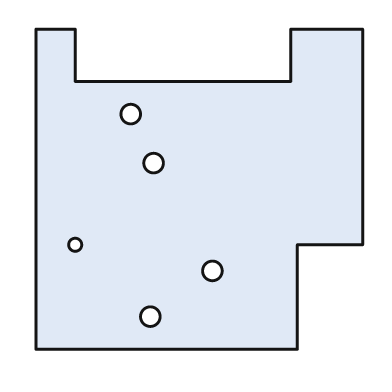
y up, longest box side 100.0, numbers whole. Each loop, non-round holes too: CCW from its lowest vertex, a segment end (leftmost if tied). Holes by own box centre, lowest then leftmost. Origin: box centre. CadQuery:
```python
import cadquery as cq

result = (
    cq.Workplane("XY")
    .moveTo(-50.0, -49.0)
    .lineTo(30.0, -49.0)
    .lineTo(30.0, -17.0)
    .lineTo(50.0, -17.0)
    .lineTo(50.0, 49.0)
    .lineTo(28.0, 49.0)
    .lineTo(28.0, 33.0)
    .lineTo(-38.0, 33.0)
    .lineTo(-38.0, 49.0)
    .lineTo(-50.0, 49.0)
    .close()
    .moveTo(-15.0, -39.0)
    .circle(3.0)
    .moveTo(4.0, -25.0)
    .circle(3.0)
    .moveTo(-38.0, -17.0)
    .circle(2.0)
    .moveTo(-14.0, 8.0)
    .circle(3.0)
    .moveTo(-21.0, 23.0)
    .circle(3.0)
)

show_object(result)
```